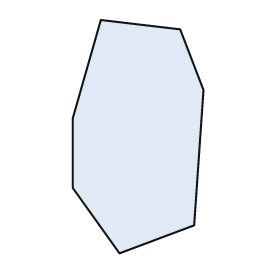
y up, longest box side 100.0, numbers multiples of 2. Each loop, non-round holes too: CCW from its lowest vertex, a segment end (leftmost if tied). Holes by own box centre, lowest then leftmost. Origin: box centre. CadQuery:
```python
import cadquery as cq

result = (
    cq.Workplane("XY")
    .moveTo(-8.0, -50.0)
    .lineTo(24.0, -38.0)
    .lineTo(28.0, 20.0)
    .lineTo(18.0, 46.0)
    .lineTo(-16.0, 50.0)
    .lineTo(-28.0, 8.0)
    .lineTo(-28.0, -22.0)
    .close()
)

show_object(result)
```